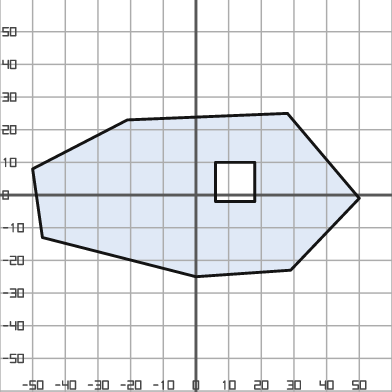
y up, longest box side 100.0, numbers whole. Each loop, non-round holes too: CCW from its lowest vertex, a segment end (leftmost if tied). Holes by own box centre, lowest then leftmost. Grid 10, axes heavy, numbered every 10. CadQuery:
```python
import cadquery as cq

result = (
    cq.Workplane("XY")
    .moveTo(0.0, -25.0)
    .lineTo(29.0, -23.0)
    .lineTo(50.0, -1.0)
    .lineTo(28.0, 25.0)
    .lineTo(-21.0, 23.0)
    .lineTo(-50.0, 8.0)
    .lineTo(-47.0, -13.0)
    .close()
    .moveTo(6.0, -2.0)
    .lineTo(18.0, -2.0)
    .lineTo(18.0, 10.0)
    .lineTo(6.0, 10.0)
    .close()
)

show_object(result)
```